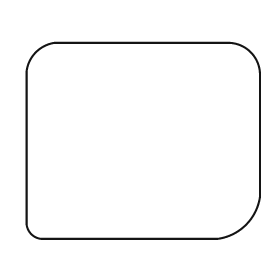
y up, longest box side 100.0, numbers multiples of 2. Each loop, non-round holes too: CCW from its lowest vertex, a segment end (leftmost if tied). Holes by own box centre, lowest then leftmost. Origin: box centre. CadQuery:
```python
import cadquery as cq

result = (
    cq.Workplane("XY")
    .moveTo(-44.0, -42.0)
    .lineTo(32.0, -42.0)
    .threePointArc((44.0, -36.0), (50.0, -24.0))
    .lineTo(50.0, 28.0)
    .threePointArc((46.0, 38.0), (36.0, 42.0))
    .lineTo(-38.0, 42.0)
    .threePointArc((-46.0, 38.0), (-50.0, 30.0))
    .lineTo(-50.0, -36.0)
    .threePointArc((-48.0, -40.0), (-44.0, -42.0))
    .close()
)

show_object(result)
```